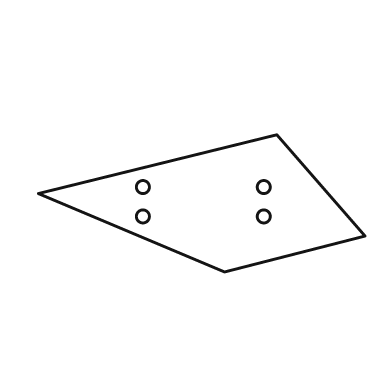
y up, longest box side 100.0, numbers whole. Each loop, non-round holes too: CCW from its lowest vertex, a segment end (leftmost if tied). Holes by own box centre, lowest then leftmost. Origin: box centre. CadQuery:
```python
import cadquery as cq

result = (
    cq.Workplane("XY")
    .moveTo(7.0, -21.0)
    .lineTo(50.0, -10.0)
    .lineTo(23.0, 21.0)
    .lineTo(-50.0, 3.0)
    .close()
    .moveTo(-18.0, -4.0)
    .circle(2.0)
    .moveTo(19.0, -4.0)
    .circle(2.0)
    .moveTo(-18.0, 5.0)
    .circle(2.0)
    .moveTo(19.0, 5.0)
    .circle(2.0)
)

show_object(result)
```